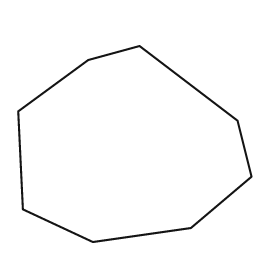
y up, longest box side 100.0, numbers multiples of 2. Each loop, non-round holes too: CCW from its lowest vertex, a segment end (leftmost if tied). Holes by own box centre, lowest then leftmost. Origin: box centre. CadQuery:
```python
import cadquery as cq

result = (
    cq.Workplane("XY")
    .moveTo(-18.0, -42.0)
    .lineTo(24.0, -36.0)
    .lineTo(50.0, -14.0)
    .lineTo(44.0, 10.0)
    .lineTo(2.0, 42.0)
    .lineTo(-20.0, 36.0)
    .lineTo(-50.0, 14.0)
    .lineTo(-48.0, -28.0)
    .close()
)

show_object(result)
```